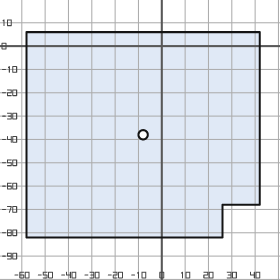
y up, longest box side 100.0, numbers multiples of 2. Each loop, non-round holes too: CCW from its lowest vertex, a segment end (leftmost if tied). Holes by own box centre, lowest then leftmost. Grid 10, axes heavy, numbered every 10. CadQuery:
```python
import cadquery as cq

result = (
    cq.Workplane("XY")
    .moveTo(-58.0, -82.0)
    .lineTo(26.0, -82.0)
    .lineTo(26.0, -68.0)
    .lineTo(42.0, -68.0)
    .lineTo(42.0, 6.0)
    .lineTo(-58.0, 6.0)
    .close()
    .moveTo(-8.0, -38.0)
    .circle(2.0)
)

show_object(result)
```